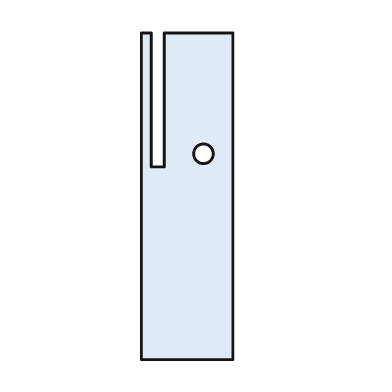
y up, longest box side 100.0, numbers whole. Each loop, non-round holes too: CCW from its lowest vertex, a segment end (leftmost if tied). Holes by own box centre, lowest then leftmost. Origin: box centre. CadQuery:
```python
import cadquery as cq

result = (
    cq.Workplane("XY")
    .moveTo(-14.0, -50.0)
    .lineTo(14.0, -50.0)
    .lineTo(14.0, 50.0)
    .lineTo(-7.0, 50.0)
    .lineTo(-7.0, 9.0)
    .lineTo(-11.0, 9.0)
    .lineTo(-11.0, 50.0)
    .lineTo(-14.0, 50.0)
    .close()
    .moveTo(5.0, 13.0)
    .circle(3.0)
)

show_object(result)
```